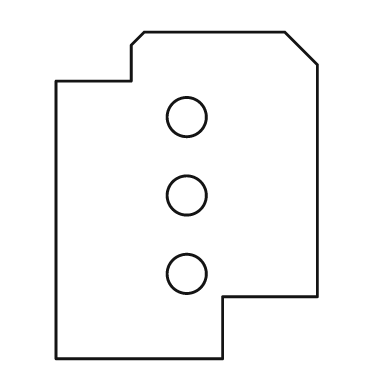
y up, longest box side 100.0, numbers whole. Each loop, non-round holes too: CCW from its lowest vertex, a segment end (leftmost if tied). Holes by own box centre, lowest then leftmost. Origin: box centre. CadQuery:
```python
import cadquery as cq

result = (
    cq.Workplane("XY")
    .moveTo(-40.0, -50.0)
    .lineTo(11.0, -50.0)
    .lineTo(11.0, -31.0)
    .lineTo(40.0, -31.0)
    .lineTo(40.0, 40.0)
    .lineTo(30.0, 50.0)
    .lineTo(-13.0, 50.0)
    .lineTo(-17.0, 46.0)
    .lineTo(-17.0, 35.0)
    .lineTo(-40.0, 35.0)
    .close()
    .moveTo(0.0, -24.0)
    .circle(6.0)
    .moveTo(0.0, 0.0)
    .circle(6.0)
    .moveTo(0.0, 24.0)
    .circle(6.0)
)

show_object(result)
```